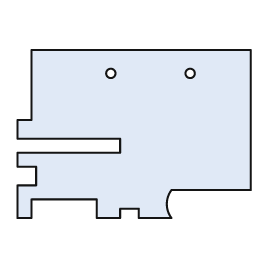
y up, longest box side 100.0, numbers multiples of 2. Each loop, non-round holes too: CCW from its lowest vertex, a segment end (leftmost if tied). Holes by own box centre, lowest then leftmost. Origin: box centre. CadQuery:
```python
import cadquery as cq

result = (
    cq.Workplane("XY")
    .moveTo(-50.0, -36.0)
    .lineTo(-44.0, -36.0)
    .lineTo(-44.0, -28.0)
    .lineTo(-16.0, -28.0)
    .lineTo(-16.0, -36.0)
    .lineTo(-6.0, -36.0)
    .lineTo(-6.0, -32.0)
    .lineTo(2.0, -32.0)
    .lineTo(2.0, -36.0)
    .lineTo(16.0, -36.0)
    .threePointArc((14.0, -30.0), (16.0, -24.0))
    .lineTo(50.0, -24.0)
    .lineTo(50.0, 36.0)
    .lineTo(-44.0, 36.0)
    .lineTo(-44.0, 6.0)
    .lineTo(-50.0, 6.0)
    .lineTo(-50.0, -2.0)
    .lineTo(-6.0, -2.0)
    .lineTo(-6.0, -8.0)
    .lineTo(-50.0, -8.0)
    .lineTo(-50.0, -14.0)
    .lineTo(-42.0, -14.0)
    .lineTo(-42.0, -22.0)
    .lineTo(-50.0, -22.0)
    .close()
    .moveTo(-10.0, 26.0)
    .circle(2.0)
    .moveTo(24.0, 26.0)
    .circle(2.0)
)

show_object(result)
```